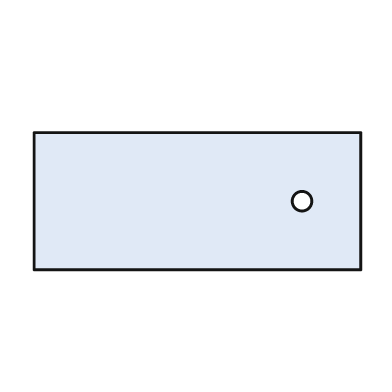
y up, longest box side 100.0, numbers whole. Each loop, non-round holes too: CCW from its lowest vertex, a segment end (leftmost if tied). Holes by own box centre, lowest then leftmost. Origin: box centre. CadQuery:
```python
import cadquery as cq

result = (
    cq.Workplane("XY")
    .moveTo(-50.0, -21.0)
    .lineTo(50.0, -21.0)
    .lineTo(50.0, 21.0)
    .lineTo(-50.0, 21.0)
    .close()
    .moveTo(32.0, 0.0)
    .circle(3.0)
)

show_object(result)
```